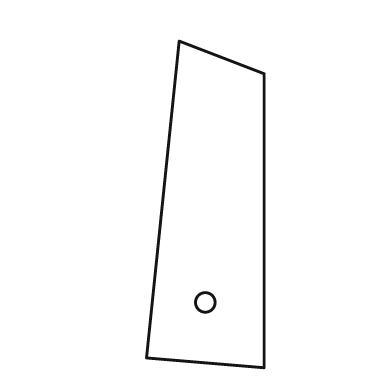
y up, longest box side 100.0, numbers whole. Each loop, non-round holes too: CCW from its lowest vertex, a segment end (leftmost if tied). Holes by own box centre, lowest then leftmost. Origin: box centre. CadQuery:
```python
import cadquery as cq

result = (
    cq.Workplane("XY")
    .moveTo(18.0, -50.0)
    .lineTo(18.0, 40.0)
    .lineTo(-8.0, 50.0)
    .lineTo(-18.0, -47.0)
    .close()
    .moveTo(0.0, -30.0)
    .circle(3.0)
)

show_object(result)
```